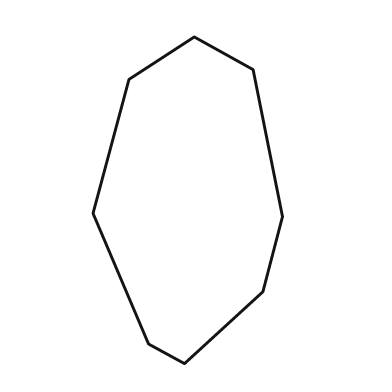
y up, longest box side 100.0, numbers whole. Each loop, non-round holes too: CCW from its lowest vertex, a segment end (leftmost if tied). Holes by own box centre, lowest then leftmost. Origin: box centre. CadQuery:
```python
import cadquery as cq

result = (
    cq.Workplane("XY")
    .moveTo(-1.0, -50.0)
    .lineTo(23.0, -28.0)
    .lineTo(29.0, -5.0)
    .lineTo(20.0, 40.0)
    .lineTo(2.0, 50.0)
    .lineTo(-18.0, 37.0)
    .lineTo(-29.0, -4.0)
    .lineTo(-12.0, -44.0)
    .close()
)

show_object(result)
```